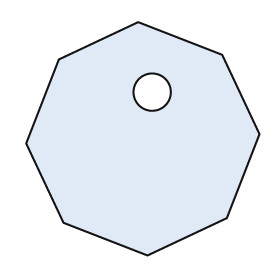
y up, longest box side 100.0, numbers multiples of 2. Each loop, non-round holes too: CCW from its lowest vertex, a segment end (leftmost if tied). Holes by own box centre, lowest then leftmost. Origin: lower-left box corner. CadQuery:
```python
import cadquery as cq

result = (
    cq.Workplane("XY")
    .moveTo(52.0, 0.0)
    .lineTo(86.0, 16.0)
    .lineTo(100.0, 52.0)
    .lineTo(84.0, 86.0)
    .lineTo(48.0, 100.0)
    .lineTo(14.0, 84.0)
    .lineTo(0.0, 48.0)
    .lineTo(16.0, 14.0)
    .close()
    .moveTo(54.0, 70.0)
    .circle(8.0)
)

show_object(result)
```